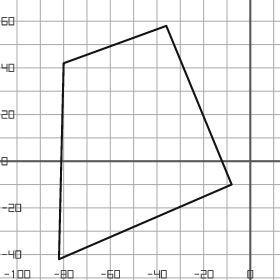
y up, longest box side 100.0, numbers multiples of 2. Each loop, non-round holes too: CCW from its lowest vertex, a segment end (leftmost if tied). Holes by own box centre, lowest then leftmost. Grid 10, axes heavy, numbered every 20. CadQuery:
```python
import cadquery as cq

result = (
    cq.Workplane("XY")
    .moveTo(-82.0, -42.0)
    .lineTo(-8.0, -10.0)
    .lineTo(-36.0, 58.0)
    .lineTo(-80.0, 42.0)
    .close()
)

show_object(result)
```